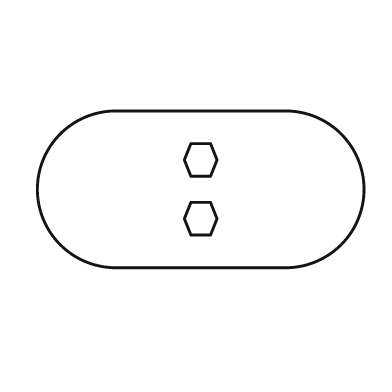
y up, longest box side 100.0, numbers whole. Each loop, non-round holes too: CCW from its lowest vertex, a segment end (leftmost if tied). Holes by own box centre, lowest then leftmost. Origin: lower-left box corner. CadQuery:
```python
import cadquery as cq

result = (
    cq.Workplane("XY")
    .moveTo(24.0, 0.0)
    .lineTo(76.0, 0.0)
    .threePointArc((100.0, 24.0), (76.0, 48.0))
    .lineTo(24.0, 48.0)
    .threePointArc((0.0, 24.0), (24.0, 0.0))
    .close()
    .moveTo(47.0, 10.0)
    .lineTo(53.0, 10.0)
    .lineTo(55.0, 15.0)
    .lineTo(53.0, 20.0)
    .lineTo(47.0, 20.0)
    .lineTo(45.0, 15.0)
    .close()
    .moveTo(47.0, 28.0)
    .lineTo(53.0, 28.0)
    .lineTo(55.0, 33.0)
    .lineTo(53.0, 38.0)
    .lineTo(47.0, 38.0)
    .lineTo(45.0, 33.0)
    .close()
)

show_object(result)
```